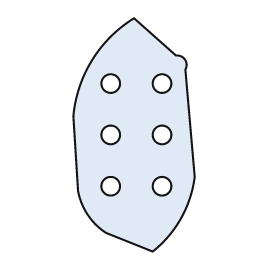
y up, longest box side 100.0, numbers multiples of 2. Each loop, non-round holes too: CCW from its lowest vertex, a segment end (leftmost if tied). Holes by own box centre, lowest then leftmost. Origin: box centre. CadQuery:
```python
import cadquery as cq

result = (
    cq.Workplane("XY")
    .moveTo(8.0, -50.0)
    .threePointArc((20.0, -36.0), (26.0, -18.0))
    .lineTo(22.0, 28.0)
    .threePointArc((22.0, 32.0), (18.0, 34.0))
    .lineTo(0.0, 50.0)
    .threePointArc((-18.0, 32.0), (-26.0, 8.0))
    .lineTo(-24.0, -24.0)
    .threePointArc((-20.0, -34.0), (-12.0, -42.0))
    .close()
    .moveTo(-10.0, -22.0)
    .circle(4.0)
    .moveTo(12.0, -22.0)
    .circle(4.0)
    .moveTo(-10.0, 0.0)
    .circle(4.0)
    .moveTo(12.0, 0.0)
    .circle(4.0)
    .moveTo(-10.0, 22.0)
    .circle(4.0)
    .moveTo(12.0, 22.0)
    .circle(4.0)
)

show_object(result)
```